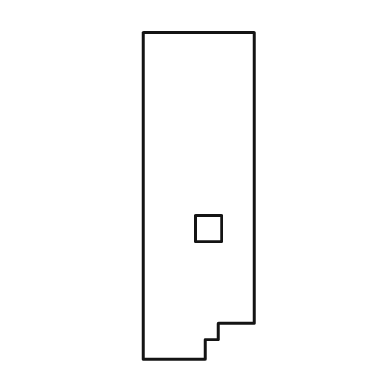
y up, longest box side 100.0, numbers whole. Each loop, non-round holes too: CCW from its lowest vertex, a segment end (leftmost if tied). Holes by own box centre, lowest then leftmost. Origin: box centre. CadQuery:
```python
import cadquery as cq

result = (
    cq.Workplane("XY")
    .moveTo(-17.0, -50.0)
    .lineTo(2.0, -50.0)
    .lineTo(2.0, -44.0)
    .lineTo(6.0, -44.0)
    .lineTo(6.0, -39.0)
    .lineTo(17.0, -39.0)
    .lineTo(17.0, 50.0)
    .lineTo(-17.0, 50.0)
    .close()
    .moveTo(-1.0, -14.0)
    .lineTo(7.0, -14.0)
    .lineTo(7.0, -6.0)
    .lineTo(-1.0, -6.0)
    .close()
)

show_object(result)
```